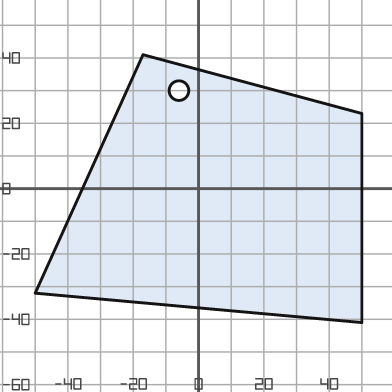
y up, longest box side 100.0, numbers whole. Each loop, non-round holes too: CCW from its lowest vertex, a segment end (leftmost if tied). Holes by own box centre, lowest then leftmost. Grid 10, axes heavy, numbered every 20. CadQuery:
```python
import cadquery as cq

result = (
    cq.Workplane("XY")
    .moveTo(50.0, -41.0)
    .lineTo(50.0, 23.0)
    .lineTo(-17.0, 41.0)
    .lineTo(-50.0, -32.0)
    .close()
    .moveTo(-6.0, 30.0)
    .circle(3.0)
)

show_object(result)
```